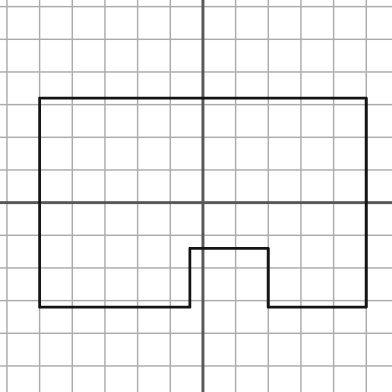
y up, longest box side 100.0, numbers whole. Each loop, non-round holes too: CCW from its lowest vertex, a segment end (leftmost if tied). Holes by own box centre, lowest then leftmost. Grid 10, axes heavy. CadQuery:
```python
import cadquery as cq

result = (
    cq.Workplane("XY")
    .moveTo(-50.0, -32.0)
    .lineTo(-4.0, -32.0)
    .lineTo(-4.0, -14.0)
    .lineTo(20.0, -14.0)
    .lineTo(20.0, -32.0)
    .lineTo(50.0, -32.0)
    .lineTo(50.0, 32.0)
    .lineTo(-50.0, 32.0)
    .close()
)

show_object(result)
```